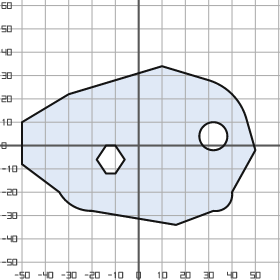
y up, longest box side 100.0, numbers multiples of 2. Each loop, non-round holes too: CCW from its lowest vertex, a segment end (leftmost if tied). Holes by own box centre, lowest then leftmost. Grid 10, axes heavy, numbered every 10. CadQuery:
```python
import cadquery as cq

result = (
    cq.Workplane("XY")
    .moveTo(16.0, -34.0)
    .lineTo(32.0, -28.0)
    .threePointArc((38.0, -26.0), (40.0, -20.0))
    .lineTo(50.0, -2.0)
    .lineTo(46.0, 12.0)
    .threePointArc((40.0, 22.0), (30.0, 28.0))
    .lineTo(10.0, 34.0)
    .lineTo(-30.0, 22.0)
    .lineTo(-50.0, 10.0)
    .lineTo(-50.0, -8.0)
    .lineTo(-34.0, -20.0)
    .threePointArc((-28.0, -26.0), (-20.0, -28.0))
    .close()
    .moveTo(-14.0, -12.0)
    .lineTo(-10.0, -12.0)
    .lineTo(-6.0, -6.0)
    .lineTo(-10.0, 0.0)
    .lineTo(-14.0, 0.0)
    .lineTo(-18.0, -6.0)
    .close()
    .moveTo(32.0, 4.0)
    .circle(6.0)
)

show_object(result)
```